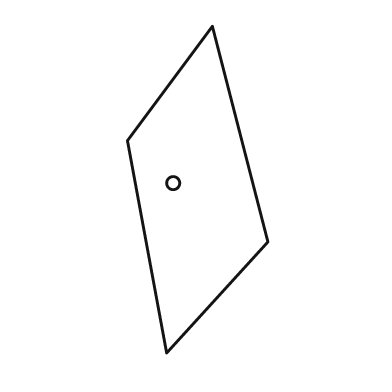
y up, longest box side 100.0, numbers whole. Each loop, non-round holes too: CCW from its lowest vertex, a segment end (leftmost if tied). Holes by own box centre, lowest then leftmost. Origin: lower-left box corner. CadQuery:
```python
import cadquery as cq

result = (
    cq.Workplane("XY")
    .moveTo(12.0, 0.0)
    .lineTo(43.0, 34.0)
    .lineTo(26.0, 100.0)
    .lineTo(0.0, 65.0)
    .close()
    .moveTo(14.0, 52.0)
    .circle(2.0)
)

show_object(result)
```